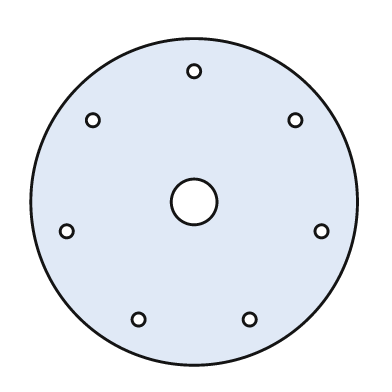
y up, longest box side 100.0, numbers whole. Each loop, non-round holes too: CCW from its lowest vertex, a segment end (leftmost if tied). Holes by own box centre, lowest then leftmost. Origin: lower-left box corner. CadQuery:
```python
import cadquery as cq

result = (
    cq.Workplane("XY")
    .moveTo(50.0, 50.0)
    .circle(50.0)
    .moveTo(33.0, 14.0)
    .circle(2.0)
    .moveTo(67.0, 14.0)
    .circle(2.0)
    .moveTo(11.0, 41.0)
    .circle(2.0)
    .moveTo(89.0, 41.0)
    .circle(2.0)
    .moveTo(50.0, 50.0)
    .circle(7.0)
    .moveTo(19.0, 75.0)
    .circle(2.0)
    .moveTo(81.0, 75.0)
    .circle(2.0)
    .moveTo(50.0, 90.0)
    .circle(2.0)
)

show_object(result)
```